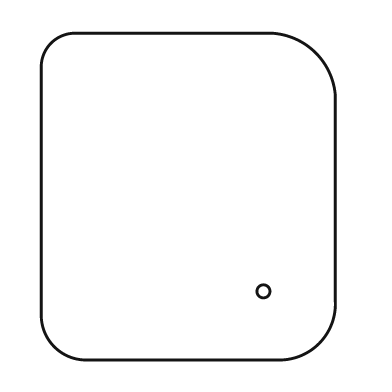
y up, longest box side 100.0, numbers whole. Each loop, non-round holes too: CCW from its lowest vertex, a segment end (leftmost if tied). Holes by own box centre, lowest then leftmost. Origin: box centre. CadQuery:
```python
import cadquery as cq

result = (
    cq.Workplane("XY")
    .moveTo(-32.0, -50.0)
    .lineTo(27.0, -50.0)
    .threePointArc((40.0, -45.0), (45.0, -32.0))
    .lineTo(45.0, 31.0)
    .threePointArc((39.0, 44.0), (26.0, 50.0))
    .lineTo(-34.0, 50.0)
    .threePointArc((-42.0, 47.0), (-45.0, 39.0))
    .lineTo(-45.0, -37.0)
    .threePointArc((-41.0, -46.0), (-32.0, -50.0))
    .close()
    .moveTo(23.0, -29.0)
    .circle(2.0)
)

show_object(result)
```